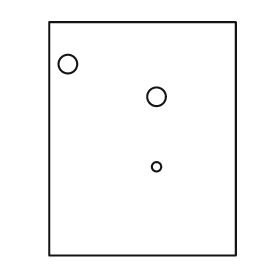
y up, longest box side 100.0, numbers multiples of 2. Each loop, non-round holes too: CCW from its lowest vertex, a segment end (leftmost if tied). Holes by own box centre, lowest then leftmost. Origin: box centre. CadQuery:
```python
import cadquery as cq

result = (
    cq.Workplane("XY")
    .moveTo(-40.0, -50.0)
    .lineTo(40.0, -50.0)
    .lineTo(40.0, 50.0)
    .lineTo(-40.0, 50.0)
    .close()
    .moveTo(6.0, -12.0)
    .circle(2.0)
    .moveTo(6.0, 18.0)
    .circle(4.0)
    .moveTo(-32.0, 32.0)
    .circle(4.0)
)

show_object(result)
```